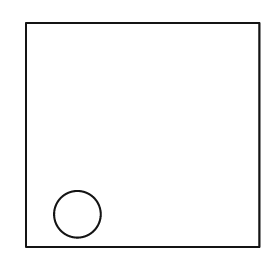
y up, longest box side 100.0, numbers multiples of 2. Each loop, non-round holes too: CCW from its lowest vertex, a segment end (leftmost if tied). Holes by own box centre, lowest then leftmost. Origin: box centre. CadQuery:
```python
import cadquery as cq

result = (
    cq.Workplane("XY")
    .moveTo(-50.0, -48.0)
    .lineTo(50.0, -48.0)
    .lineTo(50.0, 48.0)
    .lineTo(-50.0, 48.0)
    .close()
    .moveTo(-28.0, -34.0)
    .circle(10.0)
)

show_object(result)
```